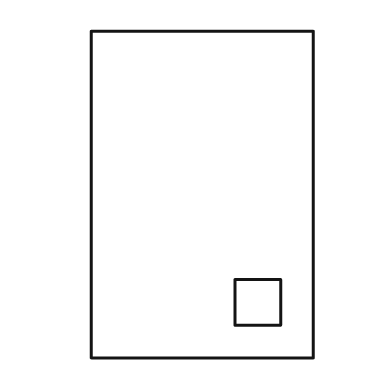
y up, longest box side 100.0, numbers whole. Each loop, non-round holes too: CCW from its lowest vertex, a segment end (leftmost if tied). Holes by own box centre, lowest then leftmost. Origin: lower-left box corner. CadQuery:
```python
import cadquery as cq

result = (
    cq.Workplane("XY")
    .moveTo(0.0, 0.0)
    .lineTo(68.0, 0.0)
    .lineTo(68.0, 100.0)
    .lineTo(0.0, 100.0)
    .close()
    .moveTo(44.0, 10.0)
    .lineTo(58.0, 10.0)
    .lineTo(58.0, 24.0)
    .lineTo(44.0, 24.0)
    .close()
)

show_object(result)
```